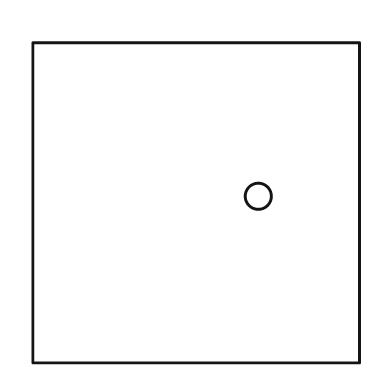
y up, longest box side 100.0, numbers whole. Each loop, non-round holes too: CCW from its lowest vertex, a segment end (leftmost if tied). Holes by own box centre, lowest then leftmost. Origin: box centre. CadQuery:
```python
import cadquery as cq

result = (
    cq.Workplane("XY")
    .moveTo(-50.0, -49.0)
    .lineTo(50.0, -49.0)
    .lineTo(50.0, 49.0)
    .lineTo(-50.0, 49.0)
    .close()
    .moveTo(19.0, 2.0)
    .circle(4.0)
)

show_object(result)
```